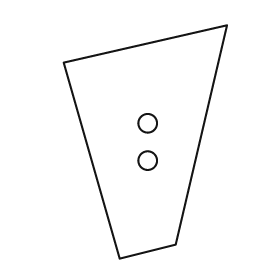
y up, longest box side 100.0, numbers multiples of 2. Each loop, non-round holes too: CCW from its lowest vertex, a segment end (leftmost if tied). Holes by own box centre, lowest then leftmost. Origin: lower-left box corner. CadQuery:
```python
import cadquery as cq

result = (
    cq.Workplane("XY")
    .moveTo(24.0, 0.0)
    .lineTo(48.0, 6.0)
    .lineTo(70.0, 100.0)
    .lineTo(0.0, 84.0)
    .close()
    .moveTo(36.0, 42.0)
    .circle(4.0)
    .moveTo(36.0, 58.0)
    .circle(4.0)
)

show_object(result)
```